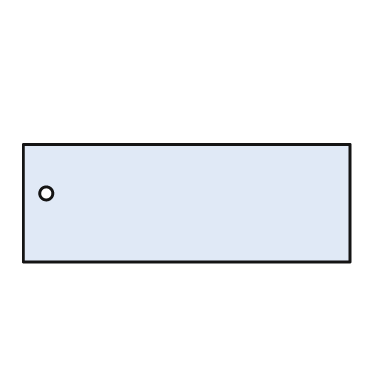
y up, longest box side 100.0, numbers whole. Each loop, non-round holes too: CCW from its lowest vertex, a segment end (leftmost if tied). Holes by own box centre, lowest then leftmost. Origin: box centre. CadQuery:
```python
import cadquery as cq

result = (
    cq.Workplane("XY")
    .moveTo(-50.0, -18.0)
    .lineTo(50.0, -18.0)
    .lineTo(50.0, 18.0)
    .lineTo(-50.0, 18.0)
    .close()
    .moveTo(-43.0, 3.0)
    .circle(2.0)
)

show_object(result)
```